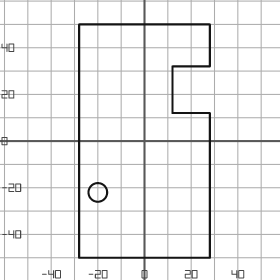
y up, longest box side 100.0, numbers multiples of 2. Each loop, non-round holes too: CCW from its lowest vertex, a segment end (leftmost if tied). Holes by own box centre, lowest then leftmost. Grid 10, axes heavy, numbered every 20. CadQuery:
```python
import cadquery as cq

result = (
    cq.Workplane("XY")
    .moveTo(-28.0, -50.0)
    .lineTo(28.0, -50.0)
    .lineTo(28.0, 12.0)
    .lineTo(12.0, 12.0)
    .lineTo(12.0, 32.0)
    .lineTo(28.0, 32.0)
    .lineTo(28.0, 50.0)
    .lineTo(-28.0, 50.0)
    .close()
    .moveTo(-20.0, -22.0)
    .circle(4.0)
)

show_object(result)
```